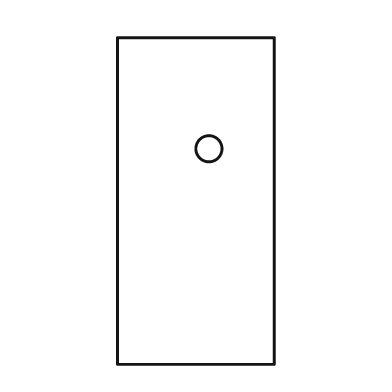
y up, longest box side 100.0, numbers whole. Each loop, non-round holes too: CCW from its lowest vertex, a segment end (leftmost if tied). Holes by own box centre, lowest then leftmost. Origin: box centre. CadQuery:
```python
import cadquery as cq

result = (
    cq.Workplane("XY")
    .moveTo(-24.0, -50.0)
    .lineTo(24.0, -50.0)
    .lineTo(24.0, 50.0)
    .lineTo(-24.0, 50.0)
    .close()
    .moveTo(4.0, 16.0)
    .circle(4.0)
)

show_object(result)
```